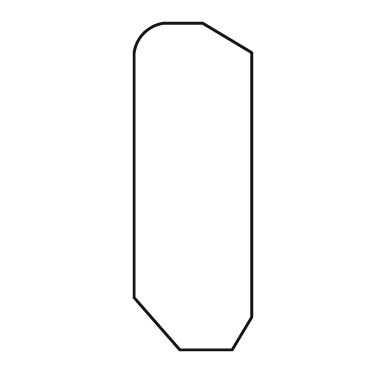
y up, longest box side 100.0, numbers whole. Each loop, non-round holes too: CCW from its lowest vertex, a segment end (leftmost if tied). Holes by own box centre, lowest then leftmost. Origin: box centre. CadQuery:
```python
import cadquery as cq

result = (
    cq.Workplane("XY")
    .moveTo(-4.0, -50.0)
    .lineTo(12.0, -50.0)
    .lineTo(18.0, -40.0)
    .lineTo(18.0, 41.0)
    .lineTo(3.0, 50.0)
    .lineTo(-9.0, 50.0)
    .threePointArc((-15.0, 47.0), (-18.0, 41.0))
    .lineTo(-18.0, -34.0)
    .close()
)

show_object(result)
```